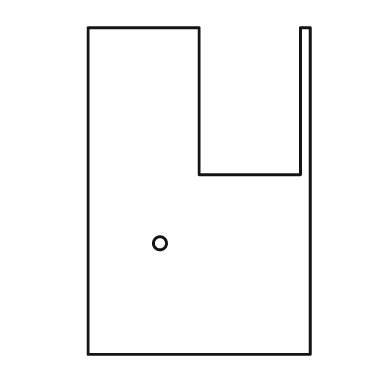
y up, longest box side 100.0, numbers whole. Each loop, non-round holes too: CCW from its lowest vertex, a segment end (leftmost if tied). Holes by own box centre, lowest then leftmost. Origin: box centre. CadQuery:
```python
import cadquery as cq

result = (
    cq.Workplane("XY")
    .moveTo(-34.0, -50.0)
    .lineTo(34.0, -50.0)
    .lineTo(34.0, 50.0)
    .lineTo(31.0, 50.0)
    .lineTo(31.0, 5.0)
    .lineTo(0.0, 5.0)
    .lineTo(0.0, 50.0)
    .lineTo(-34.0, 50.0)
    .close()
    .moveTo(-12.0, -16.0)
    .circle(2.0)
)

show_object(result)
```